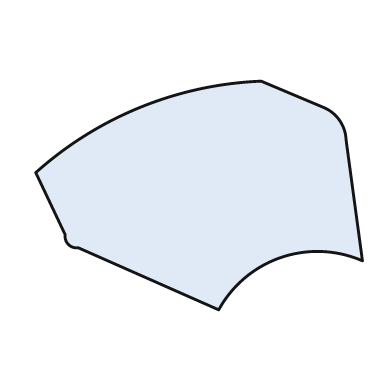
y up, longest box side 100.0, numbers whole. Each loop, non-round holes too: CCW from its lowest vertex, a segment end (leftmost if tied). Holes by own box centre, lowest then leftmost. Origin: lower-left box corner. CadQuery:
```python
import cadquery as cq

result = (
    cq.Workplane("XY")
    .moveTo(56.0, 0.0)
    .threePointArc((75.0, 16.0), (100.0, 15.0))
    .lineTo(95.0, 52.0)
    .threePointArc((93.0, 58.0), (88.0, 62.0))
    .lineTo(69.0, 70.0)
    .threePointArc((32.0, 62.0), (0.0, 42.0))
    .lineTo(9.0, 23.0)
    .threePointArc((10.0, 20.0), (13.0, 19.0))
    .close()
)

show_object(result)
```